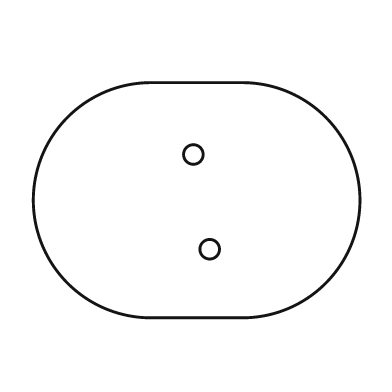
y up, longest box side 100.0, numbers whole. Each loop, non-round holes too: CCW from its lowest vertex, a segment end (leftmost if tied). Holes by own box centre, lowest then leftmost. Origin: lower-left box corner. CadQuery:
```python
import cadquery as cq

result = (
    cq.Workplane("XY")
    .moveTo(36.0, 0.0)
    .lineTo(64.0, 0.0)
    .threePointArc((100.0, 36.0), (64.0, 72.0))
    .lineTo(36.0, 72.0)
    .threePointArc((0.0, 36.0), (36.0, 0.0))
    .close()
    .moveTo(54.0, 21.0)
    .circle(3.0)
    .moveTo(49.0, 50.0)
    .circle(3.0)
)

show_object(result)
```